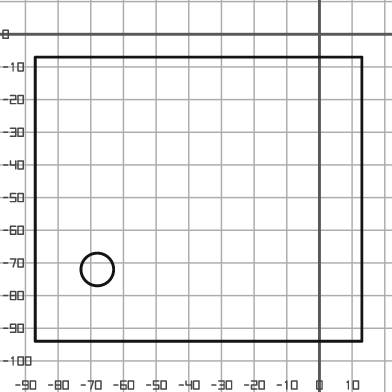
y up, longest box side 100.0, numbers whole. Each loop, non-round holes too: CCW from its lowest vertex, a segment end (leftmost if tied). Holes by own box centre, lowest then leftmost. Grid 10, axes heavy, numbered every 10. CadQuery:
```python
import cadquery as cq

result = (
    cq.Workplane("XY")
    .moveTo(-87.0, -94.0)
    .lineTo(13.0, -94.0)
    .lineTo(13.0, -7.0)
    .lineTo(-87.0, -7.0)
    .close()
    .moveTo(-68.0, -72.0)
    .circle(5.0)
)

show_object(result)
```